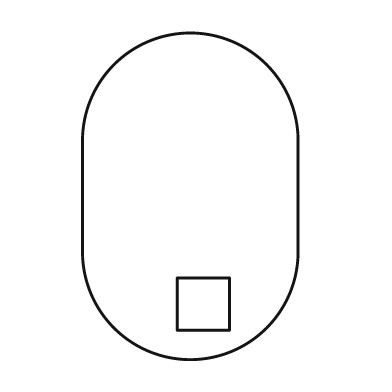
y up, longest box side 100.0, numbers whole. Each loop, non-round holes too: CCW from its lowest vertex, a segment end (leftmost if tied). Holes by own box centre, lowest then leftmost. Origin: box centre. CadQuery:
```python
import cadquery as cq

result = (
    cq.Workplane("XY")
    .moveTo(-33.0, -17.0)
    .threePointArc((0.0, -50.0), (33.0, -17.0))
    .lineTo(33.0, 17.0)
    .threePointArc((0.0, 50.0), (-33.0, 17.0))
    .close()
    .moveTo(-4.0, -41.0)
    .lineTo(12.0, -41.0)
    .lineTo(12.0, -25.0)
    .lineTo(-4.0, -25.0)
    .close()
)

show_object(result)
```